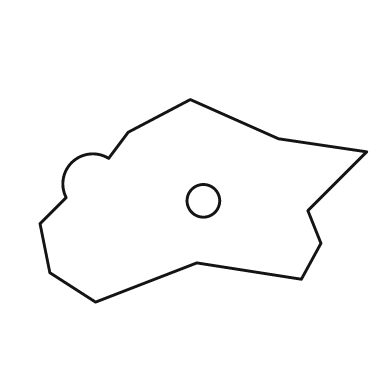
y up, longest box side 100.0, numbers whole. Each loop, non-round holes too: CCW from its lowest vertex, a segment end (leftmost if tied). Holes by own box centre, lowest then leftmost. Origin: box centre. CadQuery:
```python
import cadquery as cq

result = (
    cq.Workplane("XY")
    .moveTo(-33.0, -31.0)
    .lineTo(-2.0, -19.0)
    .lineTo(30.0, -24.0)
    .lineTo(36.0, -13.0)
    .lineTo(32.0, -3.0)
    .lineTo(50.0, 15.0)
    .lineTo(23.0, 19.0)
    .lineTo(-4.0, 31.0)
    .lineTo(-23.0, 21.0)
    .lineTo(-29.0, 13.0)
    .threePointArc((-40.0, 12.0), (-42.0, 1.0))
    .lineTo(-50.0, -7.0)
    .lineTo(-47.0, -22.0)
    .close()
    .moveTo(0.0, 0.0)
    .circle(5.0)
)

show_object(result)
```